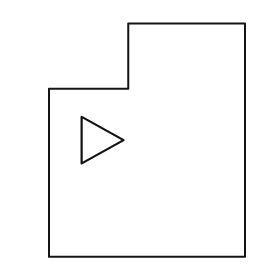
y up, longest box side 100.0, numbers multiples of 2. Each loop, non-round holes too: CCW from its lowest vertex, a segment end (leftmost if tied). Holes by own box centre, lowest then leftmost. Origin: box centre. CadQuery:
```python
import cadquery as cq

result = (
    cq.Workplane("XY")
    .moveTo(-42.0, -50.0)
    .lineTo(42.0, -50.0)
    .lineTo(42.0, 50.0)
    .lineTo(-8.0, 50.0)
    .lineTo(-8.0, 22.0)
    .lineTo(-42.0, 22.0)
    .close()
    .moveTo(-28.0, -10.0)
    .lineTo(-10.0, 0.0)
    .lineTo(-28.0, 10.0)
    .close()
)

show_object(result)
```